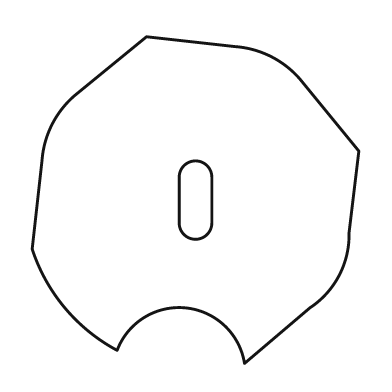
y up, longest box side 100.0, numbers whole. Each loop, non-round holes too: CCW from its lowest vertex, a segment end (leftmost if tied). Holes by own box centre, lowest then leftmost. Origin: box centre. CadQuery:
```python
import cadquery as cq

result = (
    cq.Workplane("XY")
    .moveTo(15.0, -50.0)
    .lineTo(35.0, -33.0)
    .threePointArc((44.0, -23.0), (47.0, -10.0))
    .lineTo(50.0, 15.0)
    .lineTo(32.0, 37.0)
    .threePointArc((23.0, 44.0), (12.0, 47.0))
    .lineTo(-15.0, 50.0)
    .lineTo(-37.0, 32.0)
    .threePointArc((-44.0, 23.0), (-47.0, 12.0))
    .lineTo(-50.0, -15.0)
    .threePointArc((-40.0, -33.0), (-24.0, -46.0))
    .threePointArc((-3.0, -33.0), (15.0, -50.0))
    .close()
    .moveTo(-5.0, -7.0)
    .threePointArc((0.0, -12.0), (5.0, -7.0))
    .lineTo(5.0, 7.0)
    .threePointArc((0.0, 12.0), (-5.0, 7.0))
    .close()
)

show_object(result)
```